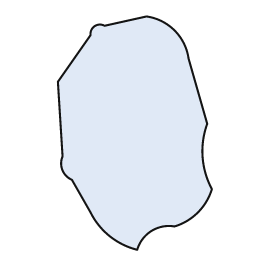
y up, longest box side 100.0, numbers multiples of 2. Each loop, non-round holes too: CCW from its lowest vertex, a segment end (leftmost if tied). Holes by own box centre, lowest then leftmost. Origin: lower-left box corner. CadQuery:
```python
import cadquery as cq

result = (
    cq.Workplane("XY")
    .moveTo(34.0, 0.0)
    .threePointArc((40.0, 8.0), (50.0, 10.0))
    .threePointArc((60.0, 16.0), (66.0, 26.0))
    .threePointArc((62.0, 40.0), (64.0, 54.0))
    .lineTo(56.0, 82.0)
    .threePointArc((50.0, 94.0), (38.0, 100.0))
    .lineTo(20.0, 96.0)
    .threePointArc((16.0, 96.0), (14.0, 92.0))
    .lineTo(0.0, 72.0)
    .lineTo(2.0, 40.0)
    .threePointArc((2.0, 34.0), (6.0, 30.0))
    .lineTo(14.0, 16.0)
    .threePointArc((22.0, 6.0), (34.0, 0.0))
    .close()
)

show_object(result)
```